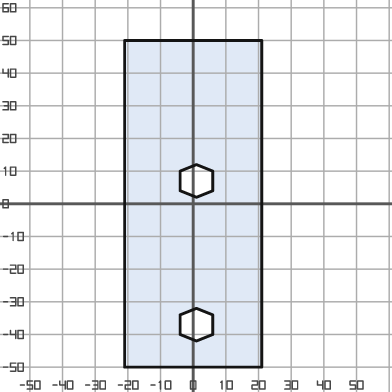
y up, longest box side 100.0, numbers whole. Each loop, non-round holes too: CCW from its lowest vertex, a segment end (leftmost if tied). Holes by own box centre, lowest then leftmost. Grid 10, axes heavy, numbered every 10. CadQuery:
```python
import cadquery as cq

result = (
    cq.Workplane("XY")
    .moveTo(-21.0, -50.0)
    .lineTo(21.0, -50.0)
    .lineTo(21.0, 50.0)
    .lineTo(-21.0, 50.0)
    .close()
    .moveTo(1.0, -42.0)
    .lineTo(6.0, -40.0)
    .lineTo(6.0, -34.0)
    .lineTo(1.0, -32.0)
    .lineTo(-4.0, -34.0)
    .lineTo(-4.0, -40.0)
    .close()
    .moveTo(1.0, 2.0)
    .lineTo(6.0, 4.0)
    .lineTo(6.0, 10.0)
    .lineTo(1.0, 12.0)
    .lineTo(-4.0, 10.0)
    .lineTo(-4.0, 4.0)
    .close()
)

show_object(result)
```